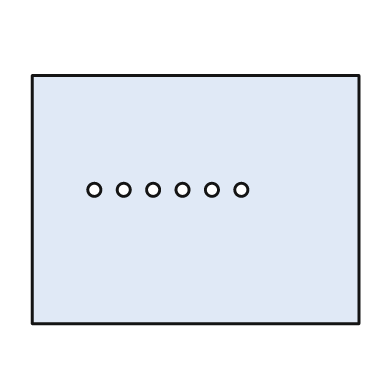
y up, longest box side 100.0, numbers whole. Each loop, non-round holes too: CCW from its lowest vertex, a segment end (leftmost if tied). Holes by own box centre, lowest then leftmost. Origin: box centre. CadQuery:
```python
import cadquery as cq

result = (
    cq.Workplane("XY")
    .moveTo(-50.0, -38.0)
    .lineTo(50.0, -38.0)
    .lineTo(50.0, 38.0)
    .lineTo(-50.0, 38.0)
    .close()
    .moveTo(-31.0, 3.0)
    .circle(2.0)
    .moveTo(-22.0, 3.0)
    .circle(2.0)
    .moveTo(-13.0, 3.0)
    .circle(2.0)
    .moveTo(-4.0, 3.0)
    .circle(2.0)
    .moveTo(5.0, 3.0)
    .circle(2.0)
    .moveTo(14.0, 3.0)
    .circle(2.0)
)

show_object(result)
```